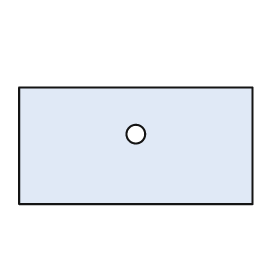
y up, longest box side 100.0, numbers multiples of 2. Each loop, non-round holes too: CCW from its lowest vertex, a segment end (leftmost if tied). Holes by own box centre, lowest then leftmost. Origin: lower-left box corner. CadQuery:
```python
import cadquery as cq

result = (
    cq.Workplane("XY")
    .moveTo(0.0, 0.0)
    .lineTo(100.0, 0.0)
    .lineTo(100.0, 50.0)
    .lineTo(0.0, 50.0)
    .close()
    .moveTo(50.0, 30.0)
    .circle(4.0)
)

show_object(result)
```